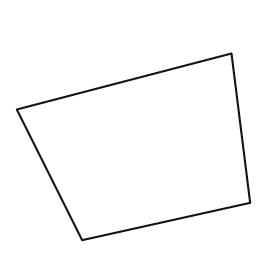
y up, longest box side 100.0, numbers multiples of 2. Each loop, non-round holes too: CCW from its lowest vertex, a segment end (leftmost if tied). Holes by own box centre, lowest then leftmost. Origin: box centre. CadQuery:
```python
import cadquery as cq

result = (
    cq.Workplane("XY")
    .moveTo(-22.0, -40.0)
    .lineTo(50.0, -24.0)
    .lineTo(42.0, 40.0)
    .lineTo(-50.0, 16.0)
    .close()
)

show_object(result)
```